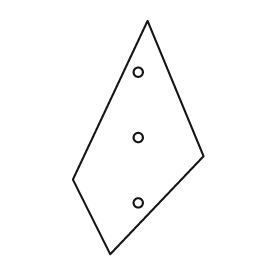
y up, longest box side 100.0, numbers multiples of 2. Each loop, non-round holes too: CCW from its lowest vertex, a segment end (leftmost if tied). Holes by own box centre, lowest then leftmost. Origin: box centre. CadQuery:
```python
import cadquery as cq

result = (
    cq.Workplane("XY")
    .moveTo(-12.0, -50.0)
    .lineTo(28.0, -8.0)
    .lineTo(4.0, 50.0)
    .lineTo(-28.0, -18.0)
    .close()
    .moveTo(0.0, -28.0)
    .circle(2.0)
    .moveTo(0.0, 0.0)
    .circle(2.0)
    .moveTo(0.0, 28.0)
    .circle(2.0)
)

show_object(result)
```